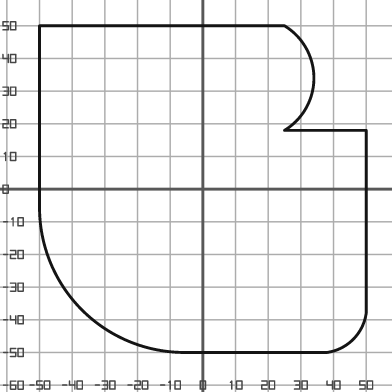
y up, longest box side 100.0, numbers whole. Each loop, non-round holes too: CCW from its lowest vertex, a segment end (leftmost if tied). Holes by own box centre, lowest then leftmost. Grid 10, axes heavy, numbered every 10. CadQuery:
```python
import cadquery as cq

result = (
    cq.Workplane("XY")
    .moveTo(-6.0, -50.0)
    .lineTo(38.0, -50.0)
    .threePointArc((46.0, -46.0), (50.0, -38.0))
    .lineTo(50.0, 18.0)
    .lineTo(25.0, 18.0)
    .threePointArc((34.0, 34.0), (25.0, 50.0))
    .lineTo(-50.0, 50.0)
    .lineTo(-50.0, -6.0)
    .threePointArc((-37.0, -37.0), (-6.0, -50.0))
    .close()
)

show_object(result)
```